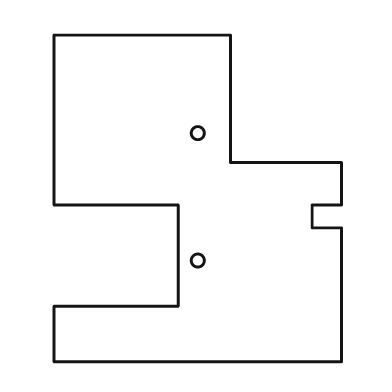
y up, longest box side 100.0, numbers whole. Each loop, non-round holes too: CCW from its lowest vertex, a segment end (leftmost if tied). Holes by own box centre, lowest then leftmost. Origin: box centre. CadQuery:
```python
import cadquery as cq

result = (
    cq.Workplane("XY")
    .moveTo(-44.0, -50.0)
    .lineTo(44.0, -50.0)
    .lineTo(44.0, -9.0)
    .lineTo(35.0, -9.0)
    .lineTo(35.0, -2.0)
    .lineTo(44.0, -2.0)
    .lineTo(44.0, 11.0)
    .lineTo(10.0, 11.0)
    .lineTo(10.0, 50.0)
    .lineTo(-44.0, 50.0)
    .lineTo(-44.0, -2.0)
    .lineTo(-6.0, -2.0)
    .lineTo(-6.0, -33.0)
    .lineTo(-44.0, -33.0)
    .close()
    .moveTo(0.0, -19.0)
    .circle(2.0)
    .moveTo(0.0, 20.0)
    .circle(2.0)
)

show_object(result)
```